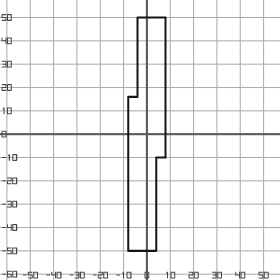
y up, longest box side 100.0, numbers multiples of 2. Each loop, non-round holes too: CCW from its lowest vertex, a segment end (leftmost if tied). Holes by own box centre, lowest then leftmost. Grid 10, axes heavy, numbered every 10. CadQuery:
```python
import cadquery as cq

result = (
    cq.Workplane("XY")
    .moveTo(-8.0, -50.0)
    .lineTo(4.0, -50.0)
    .lineTo(4.0, -10.0)
    .lineTo(8.0, -10.0)
    .lineTo(8.0, 50.0)
    .lineTo(-4.0, 50.0)
    .lineTo(-4.0, 16.0)
    .lineTo(-8.0, 16.0)
    .close()
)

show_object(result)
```